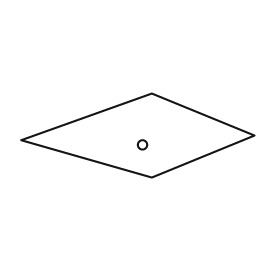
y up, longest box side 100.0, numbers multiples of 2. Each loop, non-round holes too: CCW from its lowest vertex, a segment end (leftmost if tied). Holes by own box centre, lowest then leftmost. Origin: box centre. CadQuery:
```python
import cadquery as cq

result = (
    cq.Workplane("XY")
    .moveTo(6.0, -18.0)
    .lineTo(50.0, 0.0)
    .lineTo(6.0, 18.0)
    .lineTo(-50.0, -2.0)
    .close()
    .moveTo(2.0, -4.0)
    .circle(2.0)
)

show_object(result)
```